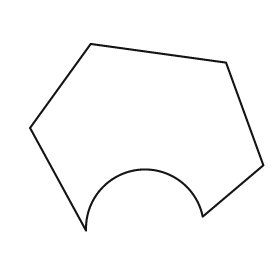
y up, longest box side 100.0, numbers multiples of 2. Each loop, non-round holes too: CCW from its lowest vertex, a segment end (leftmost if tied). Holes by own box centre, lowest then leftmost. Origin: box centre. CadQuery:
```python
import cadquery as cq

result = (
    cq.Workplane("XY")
    .moveTo(-26.0, -40.0)
    .threePointArc((-4.0, -14.0), (24.0, -34.0))
    .lineTo(50.0, -12.0)
    .lineTo(34.0, 32.0)
    .lineTo(-24.0, 40.0)
    .lineTo(-50.0, 4.0)
    .close()
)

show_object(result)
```